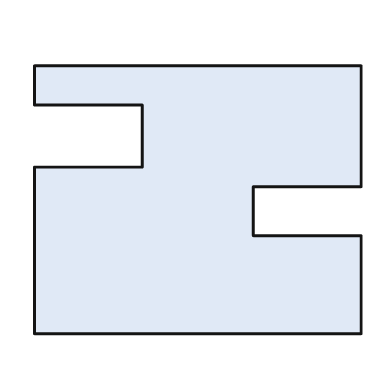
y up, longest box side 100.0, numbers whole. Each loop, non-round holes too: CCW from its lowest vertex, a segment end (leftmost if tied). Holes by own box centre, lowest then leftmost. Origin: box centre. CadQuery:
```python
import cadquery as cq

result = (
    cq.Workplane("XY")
    .moveTo(-50.0, -41.0)
    .lineTo(50.0, -41.0)
    .lineTo(50.0, -11.0)
    .lineTo(17.0, -11.0)
    .lineTo(17.0, 4.0)
    .lineTo(50.0, 4.0)
    .lineTo(50.0, 41.0)
    .lineTo(-50.0, 41.0)
    .lineTo(-50.0, 29.0)
    .lineTo(-17.0, 29.0)
    .lineTo(-17.0, 10.0)
    .lineTo(-50.0, 10.0)
    .close()
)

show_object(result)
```